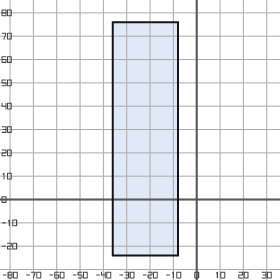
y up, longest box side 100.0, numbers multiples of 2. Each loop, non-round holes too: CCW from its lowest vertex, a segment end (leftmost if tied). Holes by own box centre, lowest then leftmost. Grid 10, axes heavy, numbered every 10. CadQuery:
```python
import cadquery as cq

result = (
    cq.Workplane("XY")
    .moveTo(-36.0, -24.0)
    .lineTo(-8.0, -24.0)
    .lineTo(-8.0, 76.0)
    .lineTo(-36.0, 76.0)
    .close()
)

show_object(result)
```